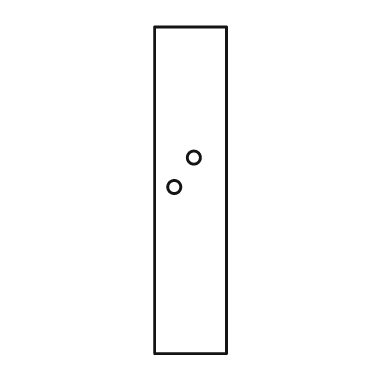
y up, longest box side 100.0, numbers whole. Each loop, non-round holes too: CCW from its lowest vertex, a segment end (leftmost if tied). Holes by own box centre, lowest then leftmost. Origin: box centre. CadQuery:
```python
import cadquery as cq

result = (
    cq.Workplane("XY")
    .moveTo(-11.0, -50.0)
    .lineTo(11.0, -50.0)
    .lineTo(11.0, 50.0)
    .lineTo(-11.0, 50.0)
    .close()
    .moveTo(-5.0, 1.0)
    .circle(2.0)
    .moveTo(1.0, 10.0)
    .circle(2.0)
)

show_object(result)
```